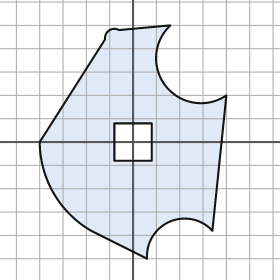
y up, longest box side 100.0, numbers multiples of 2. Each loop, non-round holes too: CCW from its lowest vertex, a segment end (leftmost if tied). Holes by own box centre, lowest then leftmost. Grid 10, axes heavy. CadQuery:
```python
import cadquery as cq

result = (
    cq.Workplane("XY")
    .moveTo(6.0, -50.0)
    .threePointArc((16.0, -34.0), (34.0, -38.0))
    .lineTo(40.0, 20.0)
    .threePointArc((14.0, 24.0), (16.0, 50.0))
    .lineTo(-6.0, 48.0)
    .threePointArc((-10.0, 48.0), (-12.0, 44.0))
    .lineTo(-40.0, 0.0)
    .threePointArc((-34.0, -22.0), (-18.0, -38.0))
    .close()
    .moveTo(-8.0, -8.0)
    .lineTo(8.0, -8.0)
    .lineTo(8.0, 8.0)
    .lineTo(-8.0, 8.0)
    .close()
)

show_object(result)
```